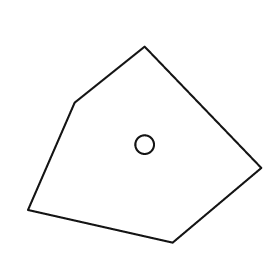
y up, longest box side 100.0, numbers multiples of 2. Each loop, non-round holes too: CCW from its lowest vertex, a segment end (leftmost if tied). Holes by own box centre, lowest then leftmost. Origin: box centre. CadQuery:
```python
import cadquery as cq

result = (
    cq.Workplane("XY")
    .moveTo(12.0, -42.0)
    .lineTo(50.0, -10.0)
    .lineTo(0.0, 42.0)
    .lineTo(-30.0, 18.0)
    .lineTo(-50.0, -28.0)
    .close()
    .moveTo(0.0, 0.0)
    .circle(4.0)
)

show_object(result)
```